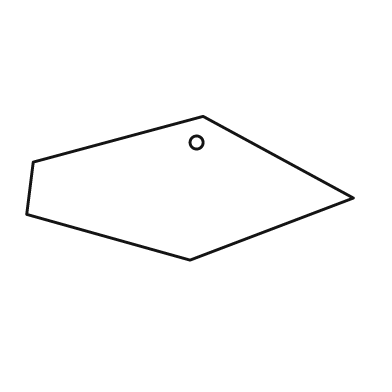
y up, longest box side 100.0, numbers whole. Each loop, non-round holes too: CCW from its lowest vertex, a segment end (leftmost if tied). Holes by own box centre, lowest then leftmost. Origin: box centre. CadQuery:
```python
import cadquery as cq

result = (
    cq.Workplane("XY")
    .moveTo(0.0, -22.0)
    .lineTo(50.0, -3.0)
    .lineTo(4.0, 22.0)
    .lineTo(-48.0, 8.0)
    .lineTo(-50.0, -8.0)
    .close()
    .moveTo(2.0, 14.0)
    .circle(2.0)
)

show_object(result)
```